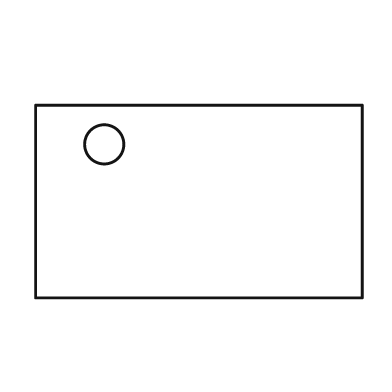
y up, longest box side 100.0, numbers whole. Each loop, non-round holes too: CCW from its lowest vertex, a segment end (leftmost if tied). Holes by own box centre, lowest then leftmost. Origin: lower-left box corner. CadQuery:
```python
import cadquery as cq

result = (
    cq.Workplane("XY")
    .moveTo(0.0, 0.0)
    .lineTo(100.0, 0.0)
    .lineTo(100.0, 59.0)
    .lineTo(0.0, 59.0)
    .close()
    .moveTo(21.0, 47.0)
    .circle(6.0)
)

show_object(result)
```